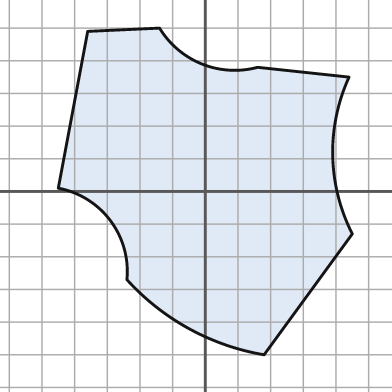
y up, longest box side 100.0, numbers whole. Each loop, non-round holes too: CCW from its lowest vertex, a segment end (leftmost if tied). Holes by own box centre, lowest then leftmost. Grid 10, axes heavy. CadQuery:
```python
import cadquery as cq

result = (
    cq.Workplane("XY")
    .moveTo(18.0, -50.0)
    .lineTo(45.0, -13.0)
    .threePointArc((39.0, 11.0), (44.0, 35.0))
    .lineTo(16.0, 38.0)
    .threePointArc((-1.0, 39.0), (-14.0, 50.0))
    .lineTo(-36.0, 49.0)
    .lineTo(-45.0, 1.0)
    .threePointArc((-29.0, -9.0), (-24.0, -27.0))
    .threePointArc((-5.0, -42.0), (18.0, -50.0))
    .close()
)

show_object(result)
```